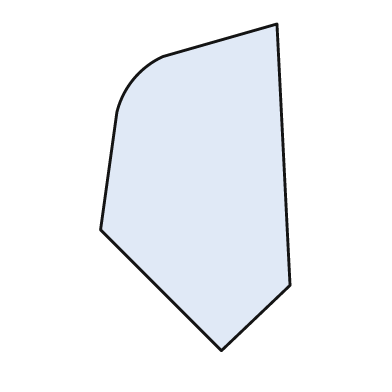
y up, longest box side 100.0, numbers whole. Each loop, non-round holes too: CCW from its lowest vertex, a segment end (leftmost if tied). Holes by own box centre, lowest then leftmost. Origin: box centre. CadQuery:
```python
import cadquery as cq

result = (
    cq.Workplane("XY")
    .moveTo(8.0, -50.0)
    .lineTo(29.0, -30.0)
    .lineTo(25.0, 50.0)
    .lineTo(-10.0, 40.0)
    .threePointArc((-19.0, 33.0), (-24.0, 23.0))
    .lineTo(-29.0, -13.0)
    .close()
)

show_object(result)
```